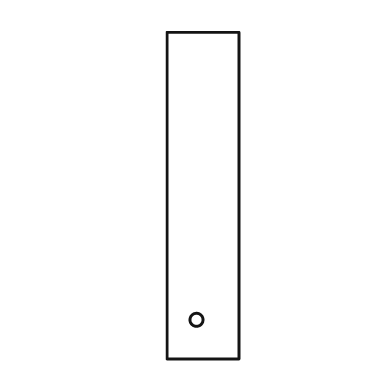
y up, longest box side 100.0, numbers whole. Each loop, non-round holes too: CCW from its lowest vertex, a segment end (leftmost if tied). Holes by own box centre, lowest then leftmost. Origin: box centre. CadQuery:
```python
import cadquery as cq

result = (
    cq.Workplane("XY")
    .moveTo(-11.0, -50.0)
    .lineTo(11.0, -50.0)
    .lineTo(11.0, 50.0)
    .lineTo(-11.0, 50.0)
    .close()
    .moveTo(-2.0, -38.0)
    .circle(2.0)
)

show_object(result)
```